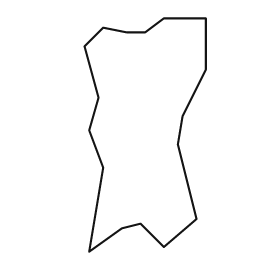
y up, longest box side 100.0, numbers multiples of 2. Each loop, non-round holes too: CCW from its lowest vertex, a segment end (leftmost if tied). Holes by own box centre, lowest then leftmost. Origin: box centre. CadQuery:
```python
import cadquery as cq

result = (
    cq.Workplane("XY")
    .moveTo(-24.0, -50.0)
    .lineTo(-10.0, -40.0)
    .lineTo(-2.0, -38.0)
    .lineTo(8.0, -48.0)
    .lineTo(22.0, -36.0)
    .lineTo(14.0, -4.0)
    .lineTo(16.0, 8.0)
    .lineTo(26.0, 28.0)
    .lineTo(26.0, 50.0)
    .lineTo(8.0, 50.0)
    .lineTo(0.0, 44.0)
    .lineTo(-8.0, 44.0)
    .lineTo(-18.0, 46.0)
    .lineTo(-26.0, 38.0)
    .lineTo(-20.0, 16.0)
    .lineTo(-24.0, 2.0)
    .lineTo(-18.0, -14.0)
    .close()
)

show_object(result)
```